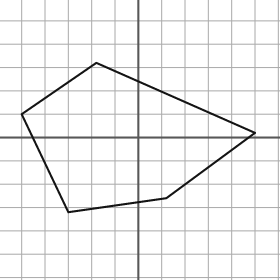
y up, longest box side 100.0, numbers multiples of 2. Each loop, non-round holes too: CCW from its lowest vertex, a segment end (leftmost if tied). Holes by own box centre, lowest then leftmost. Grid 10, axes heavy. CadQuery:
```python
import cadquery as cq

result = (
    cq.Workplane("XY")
    .moveTo(-30.0, -32.0)
    .lineTo(12.0, -26.0)
    .lineTo(50.0, 2.0)
    .lineTo(-18.0, 32.0)
    .lineTo(-50.0, 10.0)
    .close()
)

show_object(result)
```